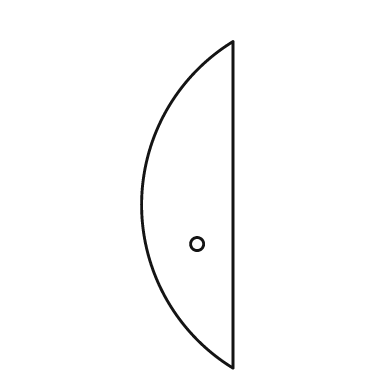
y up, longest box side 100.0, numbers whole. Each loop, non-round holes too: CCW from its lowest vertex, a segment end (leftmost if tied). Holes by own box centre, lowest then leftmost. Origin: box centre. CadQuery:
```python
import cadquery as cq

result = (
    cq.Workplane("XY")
    .moveTo(14.0, -50.0)
    .lineTo(14.0, 50.0)
    .threePointArc((-14.0, 0.0), (14.0, -50.0))
    .close()
    .moveTo(3.0, -12.0)
    .circle(2.0)
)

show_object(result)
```